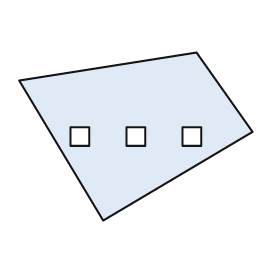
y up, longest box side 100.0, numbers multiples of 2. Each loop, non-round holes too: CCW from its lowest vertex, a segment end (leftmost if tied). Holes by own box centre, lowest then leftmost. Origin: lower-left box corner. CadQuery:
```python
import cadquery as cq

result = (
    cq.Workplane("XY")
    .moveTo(36.0, 0.0)
    .lineTo(100.0, 38.0)
    .lineTo(76.0, 72.0)
    .lineTo(0.0, 60.0)
    .close()
    .moveTo(22.0, 32.0)
    .lineTo(30.0, 32.0)
    .lineTo(30.0, 40.0)
    .lineTo(22.0, 40.0)
    .close()
    .moveTo(46.0, 32.0)
    .lineTo(54.0, 32.0)
    .lineTo(54.0, 40.0)
    .lineTo(46.0, 40.0)
    .close()
    .moveTo(70.0, 32.0)
    .lineTo(78.0, 32.0)
    .lineTo(78.0, 40.0)
    .lineTo(70.0, 40.0)
    .close()
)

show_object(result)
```